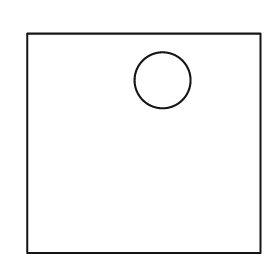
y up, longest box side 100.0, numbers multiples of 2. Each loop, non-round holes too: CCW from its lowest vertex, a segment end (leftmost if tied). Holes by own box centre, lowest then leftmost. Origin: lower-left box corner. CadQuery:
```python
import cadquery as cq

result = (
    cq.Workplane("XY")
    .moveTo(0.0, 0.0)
    .lineTo(100.0, 0.0)
    .lineTo(100.0, 94.0)
    .lineTo(0.0, 94.0)
    .close()
    .moveTo(58.0, 74.0)
    .circle(12.0)
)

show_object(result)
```